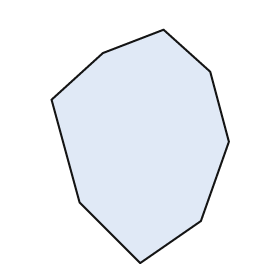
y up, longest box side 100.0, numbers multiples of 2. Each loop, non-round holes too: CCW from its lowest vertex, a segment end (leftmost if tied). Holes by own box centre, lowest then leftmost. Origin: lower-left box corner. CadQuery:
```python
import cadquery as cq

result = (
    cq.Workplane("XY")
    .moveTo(38.0, 0.0)
    .lineTo(64.0, 18.0)
    .lineTo(76.0, 52.0)
    .lineTo(68.0, 82.0)
    .lineTo(48.0, 100.0)
    .lineTo(22.0, 90.0)
    .lineTo(0.0, 70.0)
    .lineTo(12.0, 26.0)
    .close()
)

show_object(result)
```